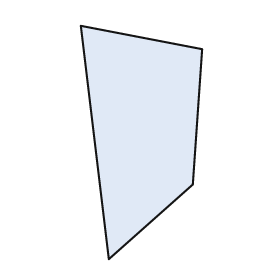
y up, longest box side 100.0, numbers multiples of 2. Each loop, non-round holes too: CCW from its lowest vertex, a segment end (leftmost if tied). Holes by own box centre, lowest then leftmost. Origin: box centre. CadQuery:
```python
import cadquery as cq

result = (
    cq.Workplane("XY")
    .moveTo(-14.0, -50.0)
    .lineTo(22.0, -18.0)
    .lineTo(26.0, 40.0)
    .lineTo(-26.0, 50.0)
    .close()
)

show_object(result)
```